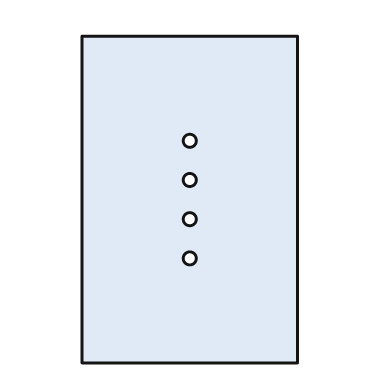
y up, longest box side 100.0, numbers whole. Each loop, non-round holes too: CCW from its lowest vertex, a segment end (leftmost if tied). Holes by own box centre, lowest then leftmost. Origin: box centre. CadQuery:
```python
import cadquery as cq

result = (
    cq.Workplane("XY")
    .moveTo(-33.0, -50.0)
    .lineTo(33.0, -50.0)
    .lineTo(33.0, 50.0)
    .lineTo(-33.0, 50.0)
    .close()
    .moveTo(0.0, -18.0)
    .circle(2.0)
    .moveTo(0.0, -6.0)
    .circle(2.0)
    .moveTo(0.0, 6.0)
    .circle(2.0)
    .moveTo(0.0, 18.0)
    .circle(2.0)
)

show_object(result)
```